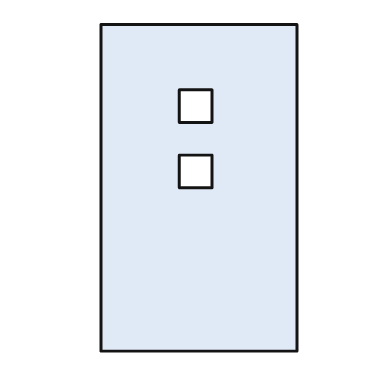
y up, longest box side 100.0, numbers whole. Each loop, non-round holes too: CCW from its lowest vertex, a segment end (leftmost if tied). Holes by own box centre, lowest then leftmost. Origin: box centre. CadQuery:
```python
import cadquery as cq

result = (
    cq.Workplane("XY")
    .moveTo(-30.0, -50.0)
    .lineTo(30.0, -50.0)
    .lineTo(30.0, 50.0)
    .lineTo(-30.0, 50.0)
    .close()
    .moveTo(-6.0, 0.0)
    .lineTo(4.0, 0.0)
    .lineTo(4.0, 10.0)
    .lineTo(-6.0, 10.0)
    .close()
    .moveTo(-6.0, 20.0)
    .lineTo(4.0, 20.0)
    .lineTo(4.0, 30.0)
    .lineTo(-6.0, 30.0)
    .close()
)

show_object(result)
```